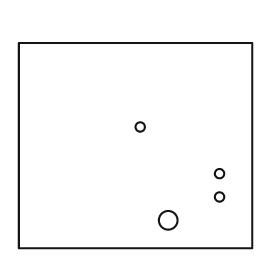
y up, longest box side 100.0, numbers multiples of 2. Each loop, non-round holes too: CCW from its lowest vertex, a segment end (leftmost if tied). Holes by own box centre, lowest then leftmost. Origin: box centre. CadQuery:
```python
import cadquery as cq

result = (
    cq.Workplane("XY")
    .moveTo(-50.0, -44.0)
    .lineTo(50.0, -44.0)
    .lineTo(50.0, 44.0)
    .lineTo(-50.0, 44.0)
    .close()
    .moveTo(14.0, -32.0)
    .circle(4.0)
    .moveTo(36.0, -22.0)
    .circle(2.0)
    .moveTo(36.0, -12.0)
    .circle(2.0)
    .moveTo(2.0, 8.0)
    .circle(2.0)
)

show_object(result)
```